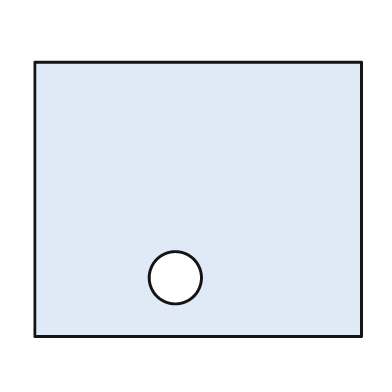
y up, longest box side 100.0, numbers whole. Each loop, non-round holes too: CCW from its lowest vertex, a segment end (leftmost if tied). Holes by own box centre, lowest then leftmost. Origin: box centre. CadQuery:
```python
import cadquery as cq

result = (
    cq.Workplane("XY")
    .moveTo(-50.0, -42.0)
    .lineTo(50.0, -42.0)
    .lineTo(50.0, 42.0)
    .lineTo(-50.0, 42.0)
    .close()
    .moveTo(-7.0, -24.0)
    .circle(8.0)
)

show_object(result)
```